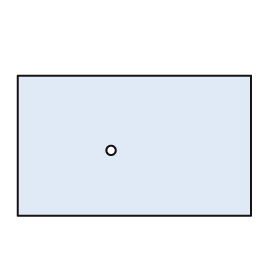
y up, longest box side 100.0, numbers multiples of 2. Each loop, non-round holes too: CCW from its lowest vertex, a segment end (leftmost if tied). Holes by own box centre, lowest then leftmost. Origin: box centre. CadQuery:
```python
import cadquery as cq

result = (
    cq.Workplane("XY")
    .moveTo(-50.0, -30.0)
    .lineTo(50.0, -30.0)
    .lineTo(50.0, 30.0)
    .lineTo(-50.0, 30.0)
    .close()
    .moveTo(-10.0, -2.0)
    .circle(2.0)
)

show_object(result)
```